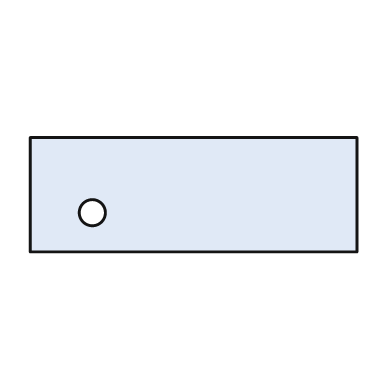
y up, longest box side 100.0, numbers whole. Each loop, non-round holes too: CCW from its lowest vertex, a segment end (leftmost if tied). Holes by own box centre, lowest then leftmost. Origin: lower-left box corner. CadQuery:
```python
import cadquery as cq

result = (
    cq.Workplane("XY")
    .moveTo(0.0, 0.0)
    .lineTo(100.0, 0.0)
    .lineTo(100.0, 35.0)
    .lineTo(0.0, 35.0)
    .close()
    .moveTo(19.0, 12.0)
    .circle(4.0)
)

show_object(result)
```